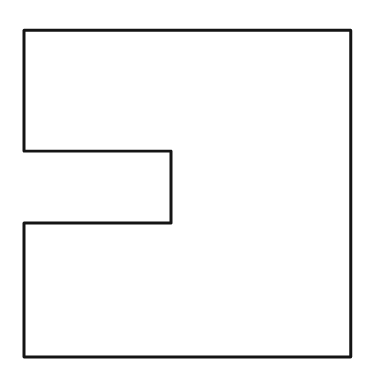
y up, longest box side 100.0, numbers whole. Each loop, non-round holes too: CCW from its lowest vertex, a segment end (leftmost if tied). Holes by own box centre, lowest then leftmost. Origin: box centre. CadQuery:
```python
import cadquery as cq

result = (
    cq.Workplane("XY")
    .moveTo(-50.0, -50.0)
    .lineTo(50.0, -50.0)
    .lineTo(50.0, 50.0)
    .lineTo(-50.0, 50.0)
    .lineTo(-50.0, 13.0)
    .lineTo(-5.0, 13.0)
    .lineTo(-5.0, -9.0)
    .lineTo(-50.0, -9.0)
    .close()
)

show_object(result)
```